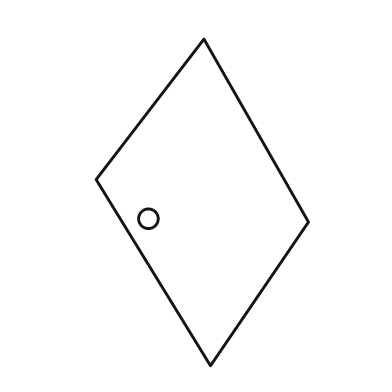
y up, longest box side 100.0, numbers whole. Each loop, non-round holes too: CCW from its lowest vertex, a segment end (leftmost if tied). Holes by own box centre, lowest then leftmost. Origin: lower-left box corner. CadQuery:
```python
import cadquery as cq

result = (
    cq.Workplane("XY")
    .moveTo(35.0, 0.0)
    .lineTo(65.0, 44.0)
    .lineTo(33.0, 100.0)
    .lineTo(0.0, 57.0)
    .close()
    .moveTo(16.0, 45.0)
    .circle(3.0)
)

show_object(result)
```